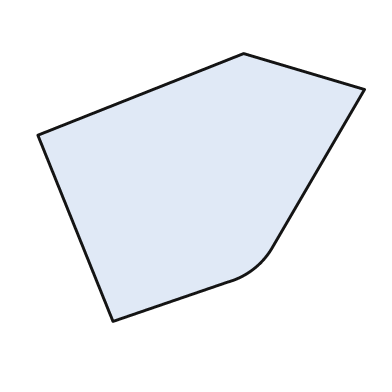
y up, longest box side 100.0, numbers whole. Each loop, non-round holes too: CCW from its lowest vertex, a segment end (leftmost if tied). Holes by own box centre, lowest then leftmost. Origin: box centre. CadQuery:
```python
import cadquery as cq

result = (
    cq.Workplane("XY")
    .moveTo(-27.0, -41.0)
    .lineTo(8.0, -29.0)
    .threePointArc((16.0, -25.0), (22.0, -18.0))
    .lineTo(50.0, 30.0)
    .lineTo(13.0, 41.0)
    .lineTo(-50.0, 16.0)
    .close()
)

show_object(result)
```